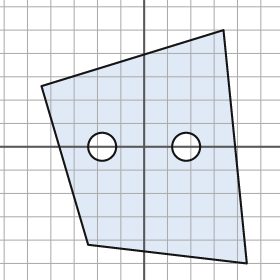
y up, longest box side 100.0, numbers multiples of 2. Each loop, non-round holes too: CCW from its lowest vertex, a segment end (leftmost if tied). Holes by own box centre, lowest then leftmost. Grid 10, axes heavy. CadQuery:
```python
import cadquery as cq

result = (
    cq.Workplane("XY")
    .moveTo(44.0, -50.0)
    .lineTo(34.0, 50.0)
    .lineTo(-44.0, 26.0)
    .lineTo(-24.0, -42.0)
    .close()
    .moveTo(-18.0, 0.0)
    .circle(6.0)
    .moveTo(18.0, 0.0)
    .circle(6.0)
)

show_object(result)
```